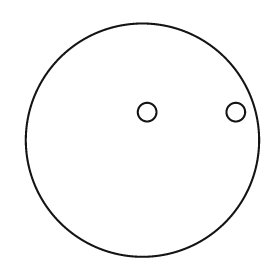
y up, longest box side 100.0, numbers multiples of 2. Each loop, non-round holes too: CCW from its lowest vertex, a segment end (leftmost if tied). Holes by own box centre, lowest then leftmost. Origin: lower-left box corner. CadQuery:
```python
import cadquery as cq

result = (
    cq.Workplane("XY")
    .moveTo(50.0, 50.0)
    .circle(50.0)
    .moveTo(52.0, 62.0)
    .circle(4.0)
    .moveTo(90.0, 62.0)
    .circle(4.0)
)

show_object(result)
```